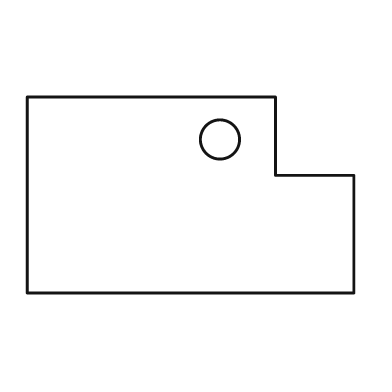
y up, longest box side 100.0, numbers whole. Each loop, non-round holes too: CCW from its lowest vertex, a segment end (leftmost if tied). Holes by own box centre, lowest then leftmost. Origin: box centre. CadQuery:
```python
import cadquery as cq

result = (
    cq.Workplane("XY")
    .moveTo(-50.0, -30.0)
    .lineTo(50.0, -30.0)
    .lineTo(50.0, 6.0)
    .lineTo(26.0, 6.0)
    .lineTo(26.0, 30.0)
    .lineTo(-50.0, 30.0)
    .close()
    .moveTo(9.0, 17.0)
    .circle(6.0)
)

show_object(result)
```